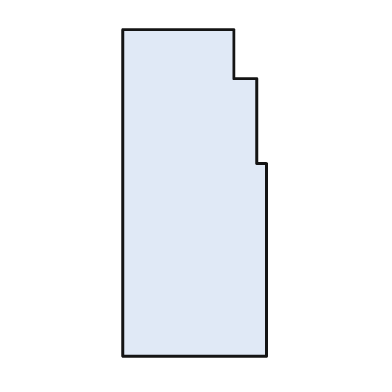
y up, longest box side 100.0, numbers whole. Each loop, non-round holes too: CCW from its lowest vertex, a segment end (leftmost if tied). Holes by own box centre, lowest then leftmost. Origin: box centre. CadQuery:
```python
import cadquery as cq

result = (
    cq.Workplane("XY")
    .moveTo(-22.0, -50.0)
    .lineTo(22.0, -50.0)
    .lineTo(22.0, 9.0)
    .lineTo(19.0, 9.0)
    .lineTo(19.0, 35.0)
    .lineTo(12.0, 35.0)
    .lineTo(12.0, 50.0)
    .lineTo(-22.0, 50.0)
    .close()
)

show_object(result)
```